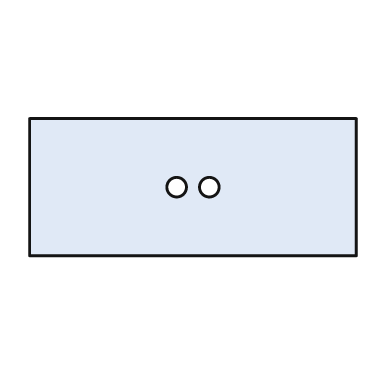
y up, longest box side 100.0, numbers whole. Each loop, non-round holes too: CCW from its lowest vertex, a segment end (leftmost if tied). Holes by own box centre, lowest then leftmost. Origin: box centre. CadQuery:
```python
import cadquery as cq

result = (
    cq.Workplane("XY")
    .moveTo(-50.0, -21.0)
    .lineTo(50.0, -21.0)
    .lineTo(50.0, 21.0)
    .lineTo(-50.0, 21.0)
    .close()
    .moveTo(-5.0, 0.0)
    .circle(3.0)
    .moveTo(5.0, 0.0)
    .circle(3.0)
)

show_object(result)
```